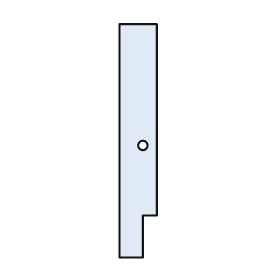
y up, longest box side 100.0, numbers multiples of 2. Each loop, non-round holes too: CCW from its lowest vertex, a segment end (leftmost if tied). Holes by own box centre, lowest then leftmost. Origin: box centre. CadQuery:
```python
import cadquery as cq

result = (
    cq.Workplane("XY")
    .moveTo(-8.0, -50.0)
    .lineTo(2.0, -50.0)
    .lineTo(2.0, -32.0)
    .lineTo(8.0, -32.0)
    .lineTo(8.0, 50.0)
    .lineTo(-8.0, 50.0)
    .close()
    .moveTo(2.0, -2.0)
    .circle(2.0)
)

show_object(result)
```